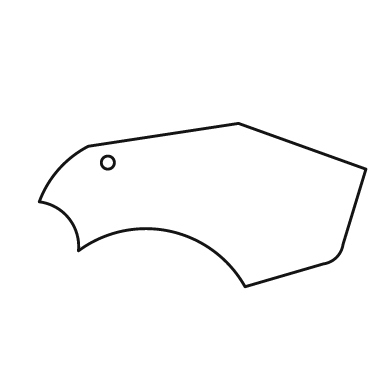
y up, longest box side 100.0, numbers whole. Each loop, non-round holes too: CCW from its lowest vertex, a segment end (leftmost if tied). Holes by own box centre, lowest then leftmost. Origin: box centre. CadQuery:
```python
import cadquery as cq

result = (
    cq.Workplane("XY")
    .moveTo(13.0, -25.0)
    .lineTo(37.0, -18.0)
    .threePointArc((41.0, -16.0), (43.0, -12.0))
    .lineTo(50.0, 11.0)
    .lineTo(11.0, 25.0)
    .lineTo(-35.0, 18.0)
    .threePointArc((-44.0, 11.0), (-50.0, 1.0))
    .threePointArc((-41.0, -4.0), (-38.0, -14.0))
    .threePointArc((-10.0, -8.0), (13.0, -25.0))
    .close()
    .moveTo(-29.0, 13.0)
    .circle(2.0)
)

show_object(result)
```